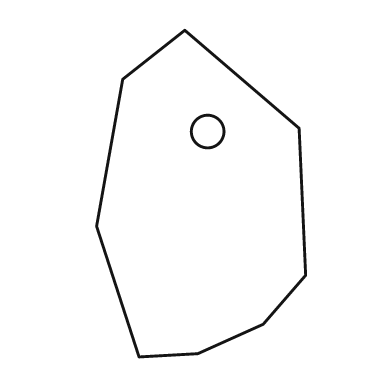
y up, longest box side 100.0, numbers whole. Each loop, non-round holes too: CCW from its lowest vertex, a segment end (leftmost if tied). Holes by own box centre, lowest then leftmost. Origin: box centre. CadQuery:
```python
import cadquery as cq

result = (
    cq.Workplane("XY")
    .moveTo(-19.0, -50.0)
    .lineTo(-1.0, -49.0)
    .lineTo(19.0, -40.0)
    .lineTo(32.0, -25.0)
    .lineTo(30.0, 20.0)
    .lineTo(-5.0, 50.0)
    .lineTo(-24.0, 35.0)
    .lineTo(-32.0, -10.0)
    .close()
    .moveTo(2.0, 19.0)
    .circle(5.0)
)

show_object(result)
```